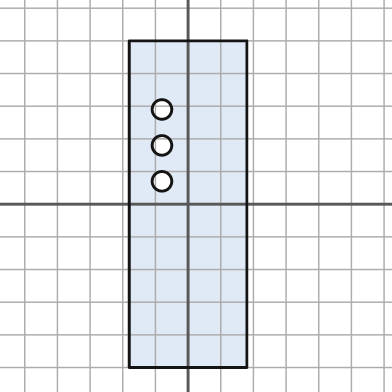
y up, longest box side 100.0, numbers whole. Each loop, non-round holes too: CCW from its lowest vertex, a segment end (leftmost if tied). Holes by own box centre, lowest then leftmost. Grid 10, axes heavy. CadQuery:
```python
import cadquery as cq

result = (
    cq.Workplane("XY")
    .moveTo(-18.0, -50.0)
    .lineTo(18.0, -50.0)
    .lineTo(18.0, 50.0)
    .lineTo(-18.0, 50.0)
    .close()
    .moveTo(-8.0, 7.0)
    .circle(3.0)
    .moveTo(-8.0, 18.0)
    .circle(3.0)
    .moveTo(-8.0, 29.0)
    .circle(3.0)
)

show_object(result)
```